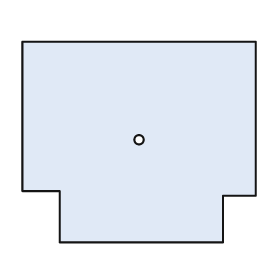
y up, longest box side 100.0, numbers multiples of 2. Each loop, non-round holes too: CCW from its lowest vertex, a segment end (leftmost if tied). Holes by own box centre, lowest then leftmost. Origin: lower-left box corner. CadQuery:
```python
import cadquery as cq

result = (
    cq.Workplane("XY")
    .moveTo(16.0, 0.0)
    .lineTo(86.0, 0.0)
    .lineTo(86.0, 20.0)
    .lineTo(100.0, 20.0)
    .lineTo(100.0, 86.0)
    .lineTo(0.0, 86.0)
    .lineTo(0.0, 22.0)
    .lineTo(16.0, 22.0)
    .close()
    .moveTo(50.0, 44.0)
    .circle(2.0)
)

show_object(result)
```